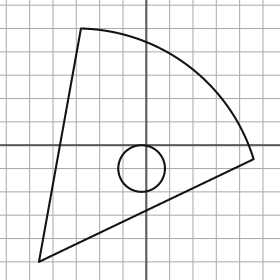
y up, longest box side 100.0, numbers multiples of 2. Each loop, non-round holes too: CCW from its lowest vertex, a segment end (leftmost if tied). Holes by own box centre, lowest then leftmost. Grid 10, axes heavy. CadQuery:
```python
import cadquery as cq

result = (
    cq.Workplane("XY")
    .moveTo(-46.0, -50.0)
    .lineTo(46.0, -6.0)
    .threePointArc((18.0, 34.0), (-28.0, 50.0))
    .close()
    .moveTo(-2.0, -10.0)
    .circle(10.0)
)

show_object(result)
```